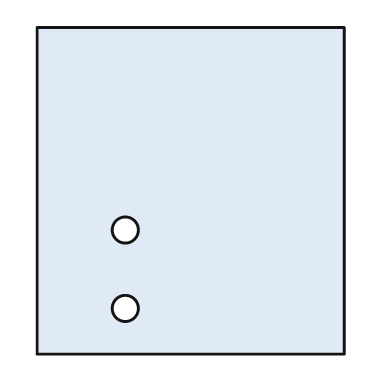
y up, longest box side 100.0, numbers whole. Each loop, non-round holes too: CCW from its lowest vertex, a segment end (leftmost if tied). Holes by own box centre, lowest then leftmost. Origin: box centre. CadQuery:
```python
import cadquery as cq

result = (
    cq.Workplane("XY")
    .moveTo(-47.0, -50.0)
    .lineTo(47.0, -50.0)
    .lineTo(47.0, 50.0)
    .lineTo(-47.0, 50.0)
    .close()
    .moveTo(-20.0, -36.0)
    .circle(4.0)
    .moveTo(-20.0, -12.0)
    .circle(4.0)
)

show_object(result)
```